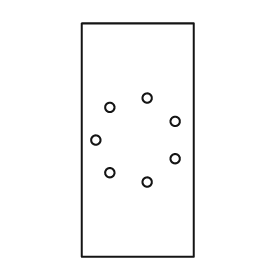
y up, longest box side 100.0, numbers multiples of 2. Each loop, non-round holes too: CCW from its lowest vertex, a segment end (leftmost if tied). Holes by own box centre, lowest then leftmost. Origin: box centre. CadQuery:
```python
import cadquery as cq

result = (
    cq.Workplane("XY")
    .moveTo(-24.0, -50.0)
    .lineTo(24.0, -50.0)
    .lineTo(24.0, 50.0)
    .lineTo(-24.0, 50.0)
    .close()
    .moveTo(4.0, -18.0)
    .circle(2.0)
    .moveTo(-12.0, -14.0)
    .circle(2.0)
    .moveTo(16.0, -8.0)
    .circle(2.0)
    .moveTo(-18.0, 0.0)
    .circle(2.0)
    .moveTo(16.0, 8.0)
    .circle(2.0)
    .moveTo(-12.0, 14.0)
    .circle(2.0)
    .moveTo(4.0, 18.0)
    .circle(2.0)
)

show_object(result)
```